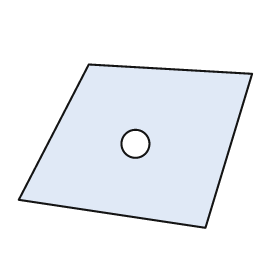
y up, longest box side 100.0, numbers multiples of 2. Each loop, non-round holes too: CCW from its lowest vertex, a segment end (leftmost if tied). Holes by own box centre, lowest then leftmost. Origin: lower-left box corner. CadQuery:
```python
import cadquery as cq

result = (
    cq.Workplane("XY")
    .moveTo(80.0, 0.0)
    .lineTo(100.0, 66.0)
    .lineTo(30.0, 70.0)
    .lineTo(0.0, 12.0)
    .close()
    .moveTo(50.0, 36.0)
    .circle(6.0)
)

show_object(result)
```